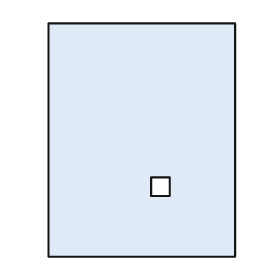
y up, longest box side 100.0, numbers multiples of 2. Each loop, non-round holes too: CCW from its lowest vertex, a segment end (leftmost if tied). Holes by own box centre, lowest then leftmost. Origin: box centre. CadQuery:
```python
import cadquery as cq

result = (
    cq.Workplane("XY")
    .moveTo(-40.0, -50.0)
    .lineTo(40.0, -50.0)
    .lineTo(40.0, 50.0)
    .lineTo(-40.0, 50.0)
    .close()
    .moveTo(4.0, -24.0)
    .lineTo(12.0, -24.0)
    .lineTo(12.0, -16.0)
    .lineTo(4.0, -16.0)
    .close()
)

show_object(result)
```